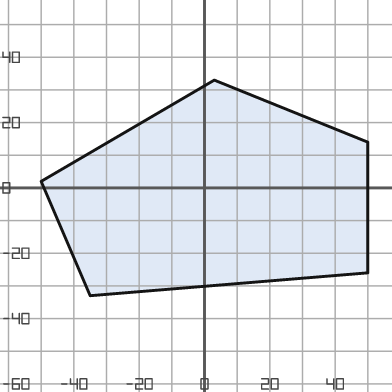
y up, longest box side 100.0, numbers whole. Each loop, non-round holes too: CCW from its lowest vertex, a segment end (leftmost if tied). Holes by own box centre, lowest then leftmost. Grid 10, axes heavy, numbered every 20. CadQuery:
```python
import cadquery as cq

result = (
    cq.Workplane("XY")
    .moveTo(-35.0, -33.0)
    .lineTo(50.0, -26.0)
    .lineTo(50.0, 14.0)
    .lineTo(3.0, 33.0)
    .lineTo(-50.0, 2.0)
    .close()
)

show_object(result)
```